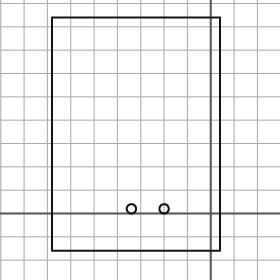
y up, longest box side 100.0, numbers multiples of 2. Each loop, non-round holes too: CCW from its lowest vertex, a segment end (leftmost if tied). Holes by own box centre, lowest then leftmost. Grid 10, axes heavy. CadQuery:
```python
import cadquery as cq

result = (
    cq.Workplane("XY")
    .moveTo(-68.0, -16.0)
    .lineTo(4.0, -16.0)
    .lineTo(4.0, 84.0)
    .lineTo(-68.0, 84.0)
    .close()
    .moveTo(-34.0, 2.0)
    .circle(2.0)
    .moveTo(-20.0, 2.0)
    .circle(2.0)
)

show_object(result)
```